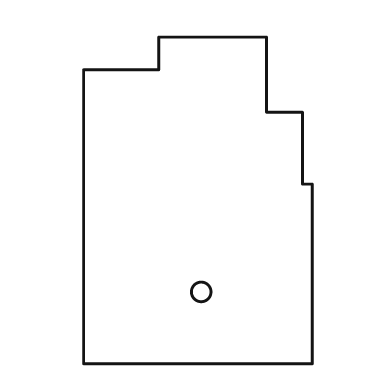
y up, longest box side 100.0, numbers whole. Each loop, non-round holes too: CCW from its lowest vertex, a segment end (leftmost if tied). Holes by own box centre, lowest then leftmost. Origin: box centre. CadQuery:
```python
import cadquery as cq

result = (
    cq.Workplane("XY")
    .moveTo(-35.0, -50.0)
    .lineTo(35.0, -50.0)
    .lineTo(35.0, 5.0)
    .lineTo(32.0, 5.0)
    .lineTo(32.0, 27.0)
    .lineTo(21.0, 27.0)
    .lineTo(21.0, 50.0)
    .lineTo(-12.0, 50.0)
    .lineTo(-12.0, 40.0)
    .lineTo(-35.0, 40.0)
    .close()
    .moveTo(1.0, -28.0)
    .circle(3.0)
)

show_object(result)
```